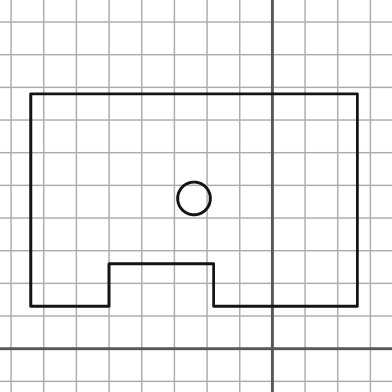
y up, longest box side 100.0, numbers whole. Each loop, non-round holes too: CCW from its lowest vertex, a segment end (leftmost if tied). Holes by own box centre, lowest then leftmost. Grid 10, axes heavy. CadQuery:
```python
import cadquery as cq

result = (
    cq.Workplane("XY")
    .moveTo(-74.0, 13.0)
    .lineTo(-50.0, 13.0)
    .lineTo(-50.0, 26.0)
    .lineTo(-18.0, 26.0)
    .lineTo(-18.0, 13.0)
    .lineTo(26.0, 13.0)
    .lineTo(26.0, 78.0)
    .lineTo(-74.0, 78.0)
    .close()
    .moveTo(-24.0, 46.0)
    .circle(5.0)
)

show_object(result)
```